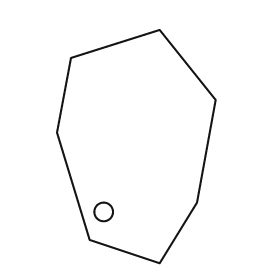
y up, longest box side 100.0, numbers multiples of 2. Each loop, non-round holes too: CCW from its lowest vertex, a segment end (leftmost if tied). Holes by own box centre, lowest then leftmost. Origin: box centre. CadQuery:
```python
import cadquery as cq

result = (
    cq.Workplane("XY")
    .moveTo(10.0, -50.0)
    .lineTo(26.0, -24.0)
    .lineTo(34.0, 20.0)
    .lineTo(10.0, 50.0)
    .lineTo(-28.0, 38.0)
    .lineTo(-34.0, 6.0)
    .lineTo(-20.0, -40.0)
    .close()
    .moveTo(-14.0, -28.0)
    .circle(4.0)
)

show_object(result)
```